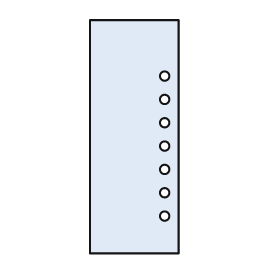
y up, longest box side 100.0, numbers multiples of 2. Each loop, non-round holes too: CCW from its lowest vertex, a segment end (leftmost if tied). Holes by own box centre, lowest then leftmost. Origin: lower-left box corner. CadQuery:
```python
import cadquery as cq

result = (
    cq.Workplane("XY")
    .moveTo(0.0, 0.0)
    .lineTo(38.0, 0.0)
    .lineTo(38.0, 100.0)
    .lineTo(0.0, 100.0)
    .close()
    .moveTo(32.0, 16.0)
    .circle(2.0)
    .moveTo(32.0, 26.0)
    .circle(2.0)
    .moveTo(32.0, 36.0)
    .circle(2.0)
    .moveTo(32.0, 46.0)
    .circle(2.0)
    .moveTo(32.0, 56.0)
    .circle(2.0)
    .moveTo(32.0, 66.0)
    .circle(2.0)
    .moveTo(32.0, 76.0)
    .circle(2.0)
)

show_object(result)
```